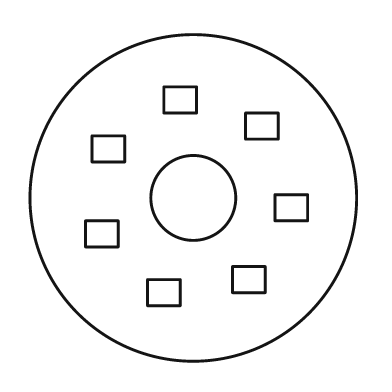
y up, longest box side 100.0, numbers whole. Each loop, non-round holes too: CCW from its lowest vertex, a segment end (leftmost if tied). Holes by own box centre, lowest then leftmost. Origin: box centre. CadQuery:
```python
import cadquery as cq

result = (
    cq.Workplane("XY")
    .moveTo(0.0, 0.0)
    .circle(50.0)
    .moveTo(-14.0, -33.0)
    .lineTo(-4.0, -33.0)
    .lineTo(-4.0, -25.0)
    .lineTo(-14.0, -25.0)
    .close()
    .moveTo(12.0, -29.0)
    .lineTo(22.0, -29.0)
    .lineTo(22.0, -21.0)
    .lineTo(12.0, -21.0)
    .close()
    .moveTo(-33.0, -15.0)
    .lineTo(-23.0, -15.0)
    .lineTo(-23.0, -7.0)
    .lineTo(-33.0, -7.0)
    .close()
    .moveTo(25.0, -7.0)
    .lineTo(35.0, -7.0)
    .lineTo(35.0, 1.0)
    .lineTo(25.0, 1.0)
    .close()
    .moveTo(0.0, 0.0)
    .circle(13.0)
    .moveTo(-31.0, 11.0)
    .lineTo(-21.0, 11.0)
    .lineTo(-21.0, 19.0)
    .lineTo(-31.0, 19.0)
    .close()
    .moveTo(16.0, 18.0)
    .lineTo(26.0, 18.0)
    .lineTo(26.0, 26.0)
    .lineTo(16.0, 26.0)
    .close()
    .moveTo(-9.0, 26.0)
    .lineTo(1.0, 26.0)
    .lineTo(1.0, 34.0)
    .lineTo(-9.0, 34.0)
    .close()
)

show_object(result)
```